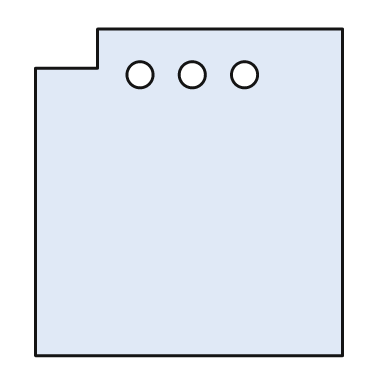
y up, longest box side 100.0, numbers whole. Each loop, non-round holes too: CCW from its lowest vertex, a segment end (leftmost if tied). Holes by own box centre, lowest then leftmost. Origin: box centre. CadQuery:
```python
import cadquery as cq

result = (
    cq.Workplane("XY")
    .moveTo(-47.0, -50.0)
    .lineTo(47.0, -50.0)
    .lineTo(47.0, 50.0)
    .lineTo(-28.0, 50.0)
    .lineTo(-28.0, 38.0)
    .lineTo(-47.0, 38.0)
    .close()
    .moveTo(-15.0, 36.0)
    .circle(4.0)
    .moveTo(1.0, 36.0)
    .circle(4.0)
    .moveTo(17.0, 36.0)
    .circle(4.0)
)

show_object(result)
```